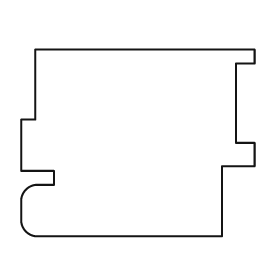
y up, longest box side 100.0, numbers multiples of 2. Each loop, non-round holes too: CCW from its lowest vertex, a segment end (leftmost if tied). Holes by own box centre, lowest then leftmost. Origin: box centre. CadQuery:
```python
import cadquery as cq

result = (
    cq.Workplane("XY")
    .moveTo(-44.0, -40.0)
    .lineTo(36.0, -40.0)
    .lineTo(36.0, -10.0)
    .lineTo(50.0, -10.0)
    .lineTo(50.0, 0.0)
    .lineTo(42.0, 0.0)
    .lineTo(42.0, 34.0)
    .lineTo(50.0, 34.0)
    .lineTo(50.0, 40.0)
    .lineTo(-44.0, 40.0)
    .lineTo(-44.0, 10.0)
    .lineTo(-50.0, 10.0)
    .lineTo(-50.0, -12.0)
    .lineTo(-36.0, -12.0)
    .lineTo(-36.0, -18.0)
    .lineTo(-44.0, -18.0)
    .threePointArc((-48.0, -20.0), (-50.0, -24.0))
    .lineTo(-50.0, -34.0)
    .threePointArc((-48.0, -38.0), (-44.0, -40.0))
    .close()
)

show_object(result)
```